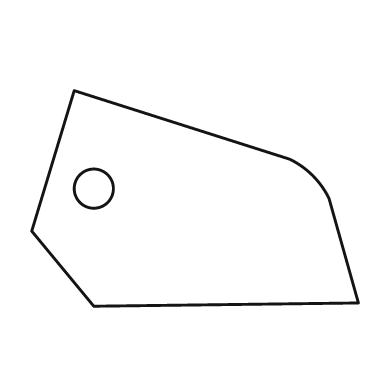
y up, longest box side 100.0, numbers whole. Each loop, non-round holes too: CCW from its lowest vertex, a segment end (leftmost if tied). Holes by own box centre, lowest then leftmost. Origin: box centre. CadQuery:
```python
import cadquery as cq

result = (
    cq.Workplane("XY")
    .moveTo(-31.0, -33.0)
    .lineTo(50.0, -32.0)
    .lineTo(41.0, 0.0)
    .threePointArc((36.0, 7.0), (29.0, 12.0))
    .lineTo(-37.0, 33.0)
    .lineTo(-50.0, -10.0)
    .close()
    .moveTo(-31.0, 3.0)
    .circle(6.0)
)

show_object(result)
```